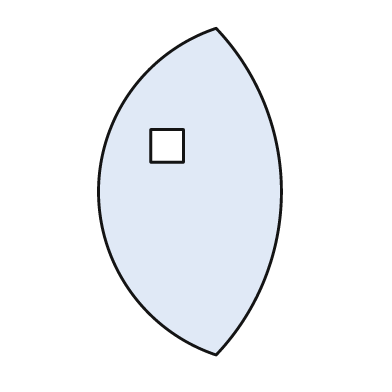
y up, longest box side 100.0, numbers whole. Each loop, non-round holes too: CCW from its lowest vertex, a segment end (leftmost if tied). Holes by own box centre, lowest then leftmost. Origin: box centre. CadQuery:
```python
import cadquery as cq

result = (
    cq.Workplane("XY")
    .moveTo(8.0, -50.0)
    .threePointArc((28.0, 0.0), (8.0, 50.0))
    .threePointArc((-28.0, 0.0), (8.0, -50.0))
    .close()
    .moveTo(-12.0, 9.0)
    .lineTo(-2.0, 9.0)
    .lineTo(-2.0, 19.0)
    .lineTo(-12.0, 19.0)
    .close()
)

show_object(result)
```